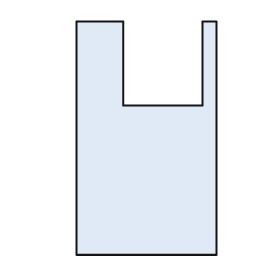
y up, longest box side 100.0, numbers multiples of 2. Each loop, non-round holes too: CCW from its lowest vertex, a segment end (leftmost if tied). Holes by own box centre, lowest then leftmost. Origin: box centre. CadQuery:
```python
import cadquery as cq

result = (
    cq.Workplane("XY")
    .moveTo(-30.0, -50.0)
    .lineTo(30.0, -50.0)
    .lineTo(30.0, 50.0)
    .lineTo(24.0, 50.0)
    .lineTo(24.0, 14.0)
    .lineTo(-10.0, 14.0)
    .lineTo(-10.0, 50.0)
    .lineTo(-30.0, 50.0)
    .close()
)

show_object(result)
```